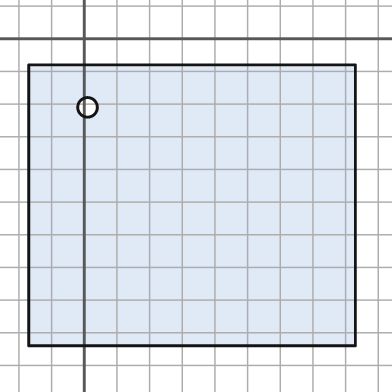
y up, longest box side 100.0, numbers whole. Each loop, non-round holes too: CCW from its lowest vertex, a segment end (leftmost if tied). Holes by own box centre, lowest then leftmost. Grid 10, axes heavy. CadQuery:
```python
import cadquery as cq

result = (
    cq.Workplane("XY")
    .moveTo(-17.0, -94.0)
    .lineTo(83.0, -94.0)
    .lineTo(83.0, -8.0)
    .lineTo(-17.0, -8.0)
    .close()
    .moveTo(1.0, -21.0)
    .circle(3.0)
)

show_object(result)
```